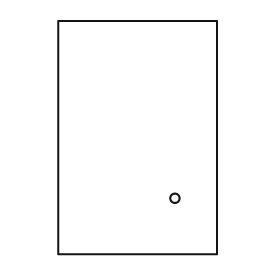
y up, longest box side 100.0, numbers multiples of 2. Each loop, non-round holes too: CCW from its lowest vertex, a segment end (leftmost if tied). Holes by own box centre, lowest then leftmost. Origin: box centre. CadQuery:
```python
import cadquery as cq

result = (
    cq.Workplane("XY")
    .moveTo(-34.0, -50.0)
    .lineTo(34.0, -50.0)
    .lineTo(34.0, 50.0)
    .lineTo(-34.0, 50.0)
    .close()
    .moveTo(16.0, -26.0)
    .circle(2.0)
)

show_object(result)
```